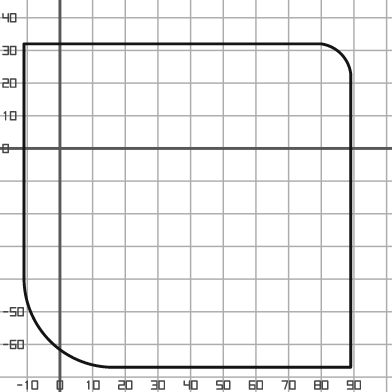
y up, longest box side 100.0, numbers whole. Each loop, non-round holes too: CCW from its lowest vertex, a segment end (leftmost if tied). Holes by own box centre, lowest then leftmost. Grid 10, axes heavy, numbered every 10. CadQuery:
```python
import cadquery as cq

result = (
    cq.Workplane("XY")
    .moveTo(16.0, -67.0)
    .lineTo(89.0, -67.0)
    .lineTo(89.0, 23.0)
    .threePointArc((86.0, 29.0), (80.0, 32.0))
    .lineTo(-11.0, 32.0)
    .lineTo(-11.0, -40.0)
    .threePointArc((-3.0, -59.0), (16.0, -67.0))
    .close()
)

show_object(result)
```